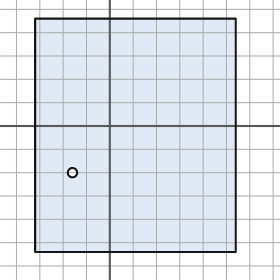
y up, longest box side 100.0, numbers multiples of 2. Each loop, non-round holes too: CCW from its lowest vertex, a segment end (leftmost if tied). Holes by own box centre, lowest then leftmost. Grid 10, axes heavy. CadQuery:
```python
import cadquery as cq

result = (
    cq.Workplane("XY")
    .moveTo(-32.0, -54.0)
    .lineTo(54.0, -54.0)
    .lineTo(54.0, 46.0)
    .lineTo(-32.0, 46.0)
    .close()
    .moveTo(-16.0, -20.0)
    .circle(2.0)
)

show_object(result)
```